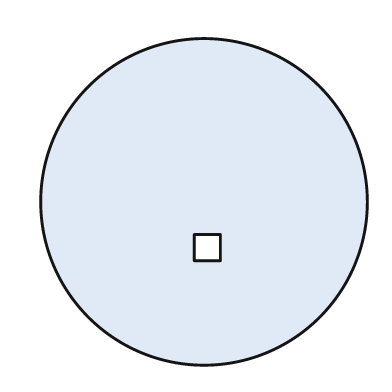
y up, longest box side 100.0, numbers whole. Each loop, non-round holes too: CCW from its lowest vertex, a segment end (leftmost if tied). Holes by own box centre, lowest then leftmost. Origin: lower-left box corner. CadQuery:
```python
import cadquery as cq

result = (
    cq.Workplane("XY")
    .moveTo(50.0, 50.0)
    .circle(50.0)
    .moveTo(47.0, 32.0)
    .lineTo(55.0, 32.0)
    .lineTo(55.0, 40.0)
    .lineTo(47.0, 40.0)
    .close()
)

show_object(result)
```